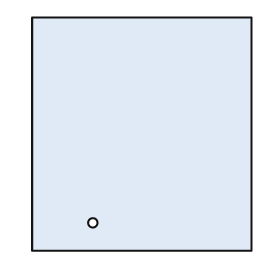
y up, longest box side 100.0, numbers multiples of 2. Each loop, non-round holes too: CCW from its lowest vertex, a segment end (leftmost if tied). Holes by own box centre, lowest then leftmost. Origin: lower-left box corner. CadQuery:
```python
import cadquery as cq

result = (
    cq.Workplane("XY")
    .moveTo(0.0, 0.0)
    .lineTo(94.0, 0.0)
    .lineTo(94.0, 100.0)
    .lineTo(0.0, 100.0)
    .close()
    .moveTo(26.0, 12.0)
    .circle(2.0)
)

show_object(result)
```